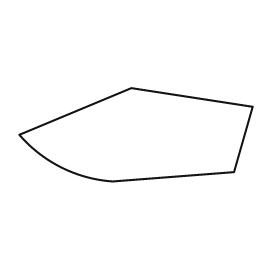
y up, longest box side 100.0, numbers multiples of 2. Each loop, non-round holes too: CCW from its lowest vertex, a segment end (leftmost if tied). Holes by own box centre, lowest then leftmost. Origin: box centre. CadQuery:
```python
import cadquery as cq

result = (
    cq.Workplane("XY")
    .moveTo(-10.0, -20.0)
    .lineTo(42.0, -16.0)
    .lineTo(50.0, 12.0)
    .lineTo(-2.0, 20.0)
    .lineTo(-50.0, 0.0)
    .threePointArc((-32.0, -14.0), (-10.0, -20.0))
    .close()
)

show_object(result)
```